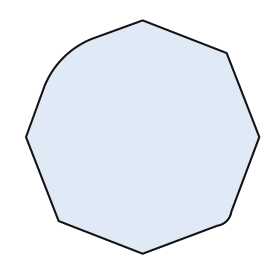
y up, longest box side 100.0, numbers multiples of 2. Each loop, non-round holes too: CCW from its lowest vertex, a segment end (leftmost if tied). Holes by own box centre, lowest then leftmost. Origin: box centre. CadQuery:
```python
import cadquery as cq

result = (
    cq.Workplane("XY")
    .moveTo(0.0, -50.0)
    .lineTo(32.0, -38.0)
    .threePointArc((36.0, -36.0), (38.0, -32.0))
    .lineTo(50.0, 0.0)
    .lineTo(36.0, 36.0)
    .lineTo(0.0, 50.0)
    .lineTo(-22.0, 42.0)
    .threePointArc((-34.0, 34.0), (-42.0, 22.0))
    .lineTo(-50.0, 0.0)
    .lineTo(-36.0, -36.0)
    .close()
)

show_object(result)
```